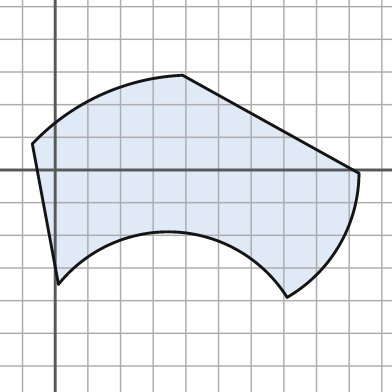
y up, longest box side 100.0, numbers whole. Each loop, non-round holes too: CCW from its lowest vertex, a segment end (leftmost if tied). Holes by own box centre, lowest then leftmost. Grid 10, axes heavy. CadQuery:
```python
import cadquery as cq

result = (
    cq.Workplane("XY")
    .moveTo(71.0, -39.0)
    .threePointArc((87.0, -23.0), (93.0, -1.0))
    .lineTo(39.0, 29.0)
    .threePointArc((14.0, 23.0), (-7.0, 8.0))
    .lineTo(1.0, -35.0)
    .threePointArc((37.0, -19.0), (71.0, -39.0))
    .close()
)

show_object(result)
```